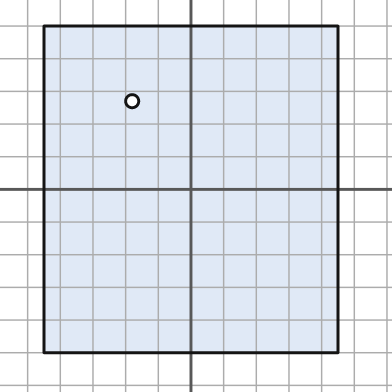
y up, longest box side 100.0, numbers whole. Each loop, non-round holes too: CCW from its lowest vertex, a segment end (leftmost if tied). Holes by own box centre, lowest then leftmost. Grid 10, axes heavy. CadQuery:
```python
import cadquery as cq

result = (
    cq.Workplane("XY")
    .moveTo(-45.0, -50.0)
    .lineTo(45.0, -50.0)
    .lineTo(45.0, 50.0)
    .lineTo(-45.0, 50.0)
    .close()
    .moveTo(-18.0, 27.0)
    .circle(2.0)
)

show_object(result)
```